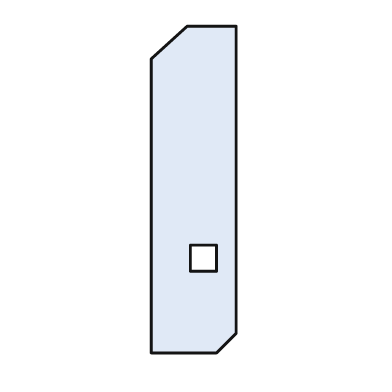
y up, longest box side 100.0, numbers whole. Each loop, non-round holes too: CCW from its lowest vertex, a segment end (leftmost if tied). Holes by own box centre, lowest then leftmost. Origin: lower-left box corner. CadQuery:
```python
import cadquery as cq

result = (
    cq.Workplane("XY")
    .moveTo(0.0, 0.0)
    .lineTo(20.0, 0.0)
    .lineTo(26.0, 6.0)
    .lineTo(26.0, 100.0)
    .lineTo(11.0, 100.0)
    .lineTo(0.0, 90.0)
    .close()
    .moveTo(12.0, 25.0)
    .lineTo(20.0, 25.0)
    .lineTo(20.0, 33.0)
    .lineTo(12.0, 33.0)
    .close()
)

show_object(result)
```